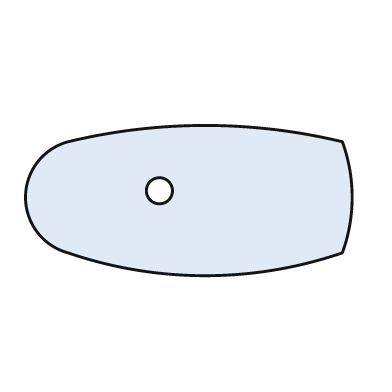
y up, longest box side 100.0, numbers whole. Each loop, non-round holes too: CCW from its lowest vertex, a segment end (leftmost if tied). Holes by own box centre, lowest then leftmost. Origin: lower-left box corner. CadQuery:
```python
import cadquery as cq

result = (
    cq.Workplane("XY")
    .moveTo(13.0, 7.0)
    .threePointArc((55.0, 0.0), (97.0, 7.0))
    .threePointArc((100.0, 24.0), (97.0, 41.0))
    .threePointArc((55.0, 46.0), (13.0, 41.0))
    .threePointArc((0.0, 24.0), (13.0, 7.0))
    .close()
    .moveTo(41.0, 26.0)
    .circle(4.0)
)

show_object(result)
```